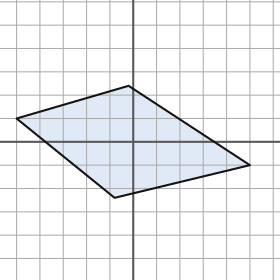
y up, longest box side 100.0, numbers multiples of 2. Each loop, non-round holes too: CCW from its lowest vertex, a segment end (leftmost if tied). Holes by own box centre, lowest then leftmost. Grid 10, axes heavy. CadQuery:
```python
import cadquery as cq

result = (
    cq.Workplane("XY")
    .moveTo(-8.0, -24.0)
    .lineTo(50.0, -10.0)
    .lineTo(-2.0, 24.0)
    .lineTo(-50.0, 10.0)
    .close()
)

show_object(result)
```